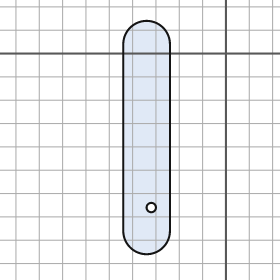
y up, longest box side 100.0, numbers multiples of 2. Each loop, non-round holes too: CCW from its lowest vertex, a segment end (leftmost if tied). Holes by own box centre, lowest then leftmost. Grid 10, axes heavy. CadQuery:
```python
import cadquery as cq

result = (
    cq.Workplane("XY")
    .moveTo(-44.0, -76.0)
    .threePointArc((-34.0, -86.0), (-24.0, -76.0))
    .lineTo(-24.0, 4.0)
    .threePointArc((-34.0, 14.0), (-44.0, 4.0))
    .close()
    .moveTo(-32.0, -66.0)
    .circle(2.0)
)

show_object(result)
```